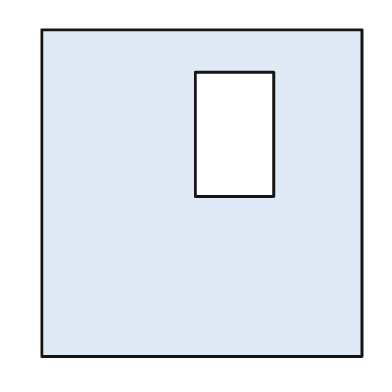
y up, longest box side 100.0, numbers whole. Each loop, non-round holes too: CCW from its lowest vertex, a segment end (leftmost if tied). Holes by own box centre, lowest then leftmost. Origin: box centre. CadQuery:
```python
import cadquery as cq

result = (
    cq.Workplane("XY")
    .moveTo(-49.0, -50.0)
    .lineTo(49.0, -50.0)
    .lineTo(49.0, 50.0)
    .lineTo(-49.0, 50.0)
    .close()
    .moveTo(-2.0, -1.0)
    .lineTo(22.0, -1.0)
    .lineTo(22.0, 37.0)
    .lineTo(-2.0, 37.0)
    .close()
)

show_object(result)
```